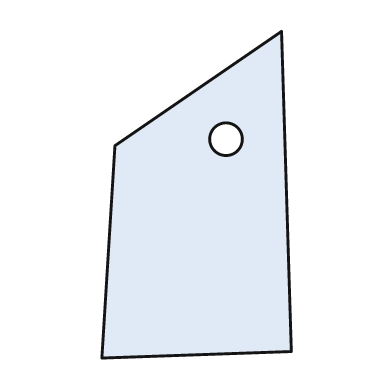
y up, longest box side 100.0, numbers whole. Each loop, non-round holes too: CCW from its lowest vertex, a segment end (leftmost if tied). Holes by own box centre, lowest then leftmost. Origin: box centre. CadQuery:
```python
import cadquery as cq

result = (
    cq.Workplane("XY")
    .moveTo(-29.0, -50.0)
    .lineTo(29.0, -48.0)
    .lineTo(26.0, 50.0)
    .lineTo(-25.0, 15.0)
    .close()
    .moveTo(9.0, 17.0)
    .circle(5.0)
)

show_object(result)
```